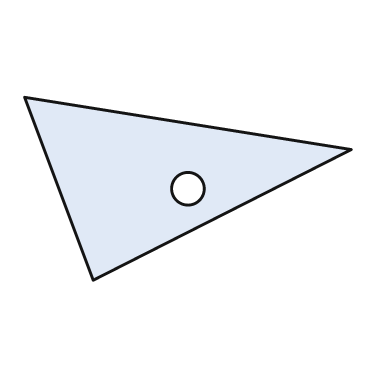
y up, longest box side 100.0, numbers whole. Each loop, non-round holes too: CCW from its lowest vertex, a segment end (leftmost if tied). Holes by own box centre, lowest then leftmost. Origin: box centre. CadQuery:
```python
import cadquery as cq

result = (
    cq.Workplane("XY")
    .moveTo(-29.0, -28.0)
    .lineTo(50.0, 12.0)
    .lineTo(-50.0, 28.0)
    .close()
    .moveTo(0.0, 0.0)
    .circle(5.0)
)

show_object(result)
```